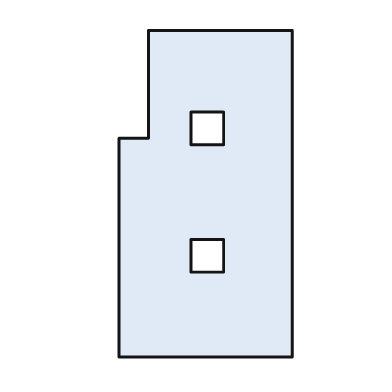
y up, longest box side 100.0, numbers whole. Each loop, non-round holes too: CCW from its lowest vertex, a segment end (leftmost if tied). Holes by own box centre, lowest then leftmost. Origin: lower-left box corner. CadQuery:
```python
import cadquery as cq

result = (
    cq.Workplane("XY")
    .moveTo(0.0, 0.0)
    .lineTo(53.0, 0.0)
    .lineTo(53.0, 100.0)
    .lineTo(9.0, 100.0)
    .lineTo(9.0, 67.0)
    .lineTo(0.0, 67.0)
    .close()
    .moveTo(22.0, 26.0)
    .lineTo(32.0, 26.0)
    .lineTo(32.0, 36.0)
    .lineTo(22.0, 36.0)
    .close()
    .moveTo(22.0, 65.0)
    .lineTo(32.0, 65.0)
    .lineTo(32.0, 75.0)
    .lineTo(22.0, 75.0)
    .close()
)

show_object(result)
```